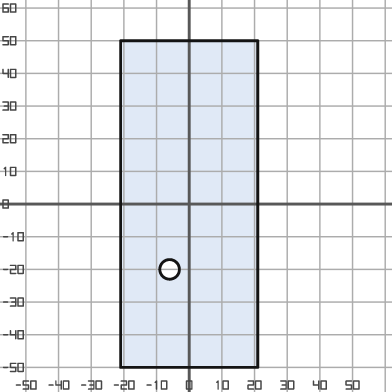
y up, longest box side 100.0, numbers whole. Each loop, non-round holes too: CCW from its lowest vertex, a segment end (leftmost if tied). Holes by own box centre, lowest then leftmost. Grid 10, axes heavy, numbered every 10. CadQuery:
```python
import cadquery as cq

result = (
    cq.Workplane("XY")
    .moveTo(-21.0, -50.0)
    .lineTo(21.0, -50.0)
    .lineTo(21.0, 50.0)
    .lineTo(-21.0, 50.0)
    .close()
    .moveTo(-6.0, -20.0)
    .circle(3.0)
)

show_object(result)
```